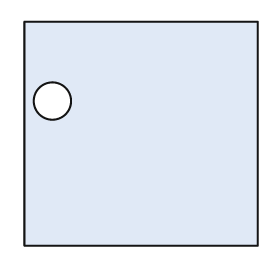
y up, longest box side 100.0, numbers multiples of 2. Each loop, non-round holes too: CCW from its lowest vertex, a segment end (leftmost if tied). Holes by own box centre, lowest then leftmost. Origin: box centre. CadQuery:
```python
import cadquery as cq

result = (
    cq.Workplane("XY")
    .moveTo(-50.0, -48.0)
    .lineTo(50.0, -48.0)
    .lineTo(50.0, 48.0)
    .lineTo(-50.0, 48.0)
    .close()
    .moveTo(-38.0, 14.0)
    .circle(8.0)
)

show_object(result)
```